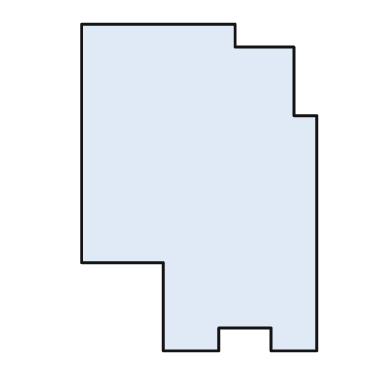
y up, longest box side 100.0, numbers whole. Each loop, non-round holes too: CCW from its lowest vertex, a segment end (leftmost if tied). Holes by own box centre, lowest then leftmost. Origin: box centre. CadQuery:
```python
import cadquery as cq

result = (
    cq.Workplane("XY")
    .moveTo(-11.0, -50.0)
    .lineTo(6.0, -50.0)
    .lineTo(6.0, -43.0)
    .lineTo(22.0, -43.0)
    .lineTo(22.0, -50.0)
    .lineTo(36.0, -50.0)
    .lineTo(36.0, 22.0)
    .lineTo(29.0, 22.0)
    .lineTo(29.0, 43.0)
    .lineTo(11.0, 43.0)
    .lineTo(11.0, 50.0)
    .lineTo(-36.0, 50.0)
    .lineTo(-36.0, -23.0)
    .lineTo(-11.0, -23.0)
    .close()
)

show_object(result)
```